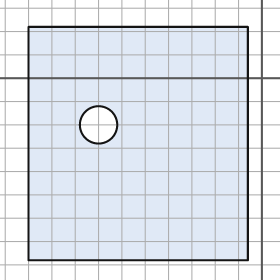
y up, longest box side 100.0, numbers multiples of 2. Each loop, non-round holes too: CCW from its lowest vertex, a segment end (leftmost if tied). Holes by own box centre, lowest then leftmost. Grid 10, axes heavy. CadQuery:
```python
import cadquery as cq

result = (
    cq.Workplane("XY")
    .moveTo(-100.0, -78.0)
    .lineTo(-6.0, -78.0)
    .lineTo(-6.0, 22.0)
    .lineTo(-100.0, 22.0)
    .close()
    .moveTo(-70.0, -20.0)
    .circle(8.0)
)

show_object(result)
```